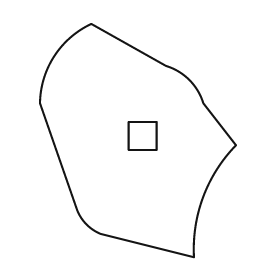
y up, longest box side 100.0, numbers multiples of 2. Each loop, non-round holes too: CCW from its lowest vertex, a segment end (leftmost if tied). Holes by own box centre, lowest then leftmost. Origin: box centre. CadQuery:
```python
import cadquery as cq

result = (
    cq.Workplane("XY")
    .moveTo(24.0, -50.0)
    .threePointArc((28.0, -24.0), (42.0, -2.0))
    .lineTo(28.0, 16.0)
    .threePointArc((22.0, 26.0), (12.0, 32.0))
    .lineTo(-20.0, 50.0)
    .threePointArc((-36.0, 36.0), (-42.0, 16.0))
    .lineTo(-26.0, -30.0)
    .threePointArc((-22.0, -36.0), (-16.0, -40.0))
    .close()
    .moveTo(-4.0, -4.0)
    .lineTo(8.0, -4.0)
    .lineTo(8.0, 8.0)
    .lineTo(-4.0, 8.0)
    .close()
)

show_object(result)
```